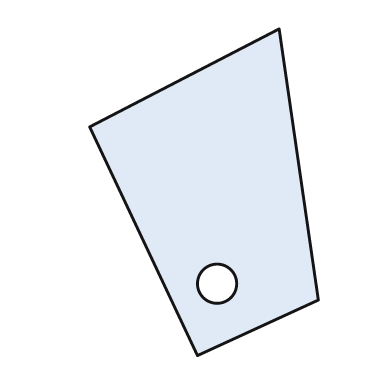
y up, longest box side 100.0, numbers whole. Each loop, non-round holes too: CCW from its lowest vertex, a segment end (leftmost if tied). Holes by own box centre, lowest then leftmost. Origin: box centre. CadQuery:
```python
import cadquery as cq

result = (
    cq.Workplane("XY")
    .moveTo(-2.0, -50.0)
    .lineTo(35.0, -33.0)
    .lineTo(23.0, 50.0)
    .lineTo(-35.0, 20.0)
    .close()
    .moveTo(4.0, -28.0)
    .circle(6.0)
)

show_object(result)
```